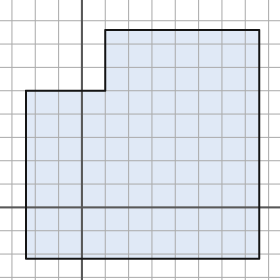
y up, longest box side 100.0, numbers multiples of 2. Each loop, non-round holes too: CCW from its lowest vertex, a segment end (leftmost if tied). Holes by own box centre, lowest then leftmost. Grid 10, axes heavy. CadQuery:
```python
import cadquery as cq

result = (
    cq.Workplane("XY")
    .moveTo(-24.0, -22.0)
    .lineTo(76.0, -22.0)
    .lineTo(76.0, 76.0)
    .lineTo(10.0, 76.0)
    .lineTo(10.0, 50.0)
    .lineTo(-24.0, 50.0)
    .close()
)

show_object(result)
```